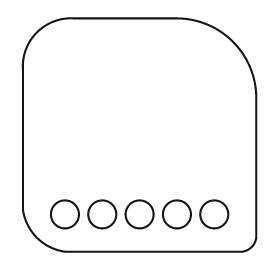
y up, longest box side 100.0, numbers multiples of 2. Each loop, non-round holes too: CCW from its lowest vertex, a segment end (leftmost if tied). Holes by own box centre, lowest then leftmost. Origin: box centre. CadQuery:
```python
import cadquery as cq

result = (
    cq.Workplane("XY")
    .moveTo(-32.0, -50.0)
    .lineTo(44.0, -50.0)
    .threePointArc((48.0, -48.0), (50.0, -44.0))
    .lineTo(50.0, 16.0)
    .threePointArc((40.0, 40.0), (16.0, 50.0))
    .lineTo(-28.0, 50.0)
    .threePointArc((-44.0, 44.0), (-50.0, 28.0))
    .lineTo(-50.0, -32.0)
    .threePointArc((-44.0, -44.0), (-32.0, -50.0))
    .close()
    .moveTo(-32.0, -34.0)
    .circle(6.0)
    .moveTo(-16.0, -34.0)
    .circle(6.0)
    .moveTo(0.0, -34.0)
    .circle(6.0)
    .moveTo(16.0, -34.0)
    .circle(6.0)
    .moveTo(32.0, -34.0)
    .circle(6.0)
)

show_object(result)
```